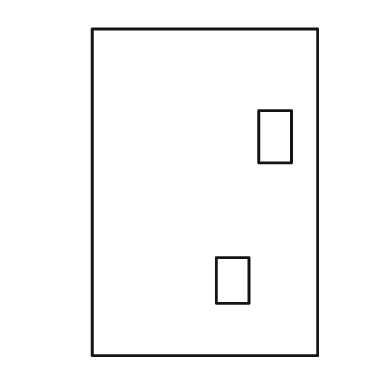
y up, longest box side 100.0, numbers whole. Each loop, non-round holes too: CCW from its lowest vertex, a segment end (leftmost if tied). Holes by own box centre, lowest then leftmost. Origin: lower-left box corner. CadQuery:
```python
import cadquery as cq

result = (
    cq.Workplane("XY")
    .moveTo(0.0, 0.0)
    .lineTo(69.0, 0.0)
    .lineTo(69.0, 100.0)
    .lineTo(0.0, 100.0)
    .close()
    .moveTo(38.0, 16.0)
    .lineTo(48.0, 16.0)
    .lineTo(48.0, 30.0)
    .lineTo(38.0, 30.0)
    .close()
    .moveTo(51.0, 59.0)
    .lineTo(61.0, 59.0)
    .lineTo(61.0, 75.0)
    .lineTo(51.0, 75.0)
    .close()
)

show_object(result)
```